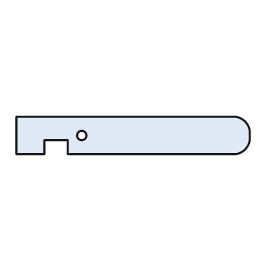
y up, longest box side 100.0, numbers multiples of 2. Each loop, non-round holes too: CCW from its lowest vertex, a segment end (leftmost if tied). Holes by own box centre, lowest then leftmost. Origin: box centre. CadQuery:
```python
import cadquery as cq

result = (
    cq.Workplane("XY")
    .moveTo(-50.0, -8.0)
    .lineTo(-38.0, -8.0)
    .lineTo(-38.0, -2.0)
    .lineTo(-28.0, -2.0)
    .lineTo(-28.0, -8.0)
    .lineTo(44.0, -8.0)
    .threePointArc((48.0, -6.0), (50.0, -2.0))
    .lineTo(50.0, 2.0)
    .threePointArc((48.0, 6.0), (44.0, 8.0))
    .lineTo(-50.0, 8.0)
    .close()
    .moveTo(-22.0, 0.0)
    .circle(2.0)
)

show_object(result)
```